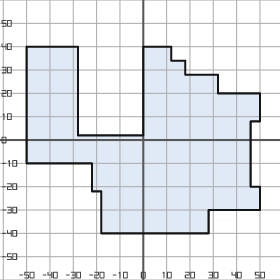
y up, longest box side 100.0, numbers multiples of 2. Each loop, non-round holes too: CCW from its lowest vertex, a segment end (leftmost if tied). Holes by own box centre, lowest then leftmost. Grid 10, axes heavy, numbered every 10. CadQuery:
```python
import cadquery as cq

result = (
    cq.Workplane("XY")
    .moveTo(-18.0, -40.0)
    .lineTo(28.0, -40.0)
    .lineTo(28.0, -30.0)
    .lineTo(50.0, -30.0)
    .lineTo(50.0, -20.0)
    .lineTo(46.0, -20.0)
    .lineTo(46.0, 8.0)
    .lineTo(50.0, 8.0)
    .lineTo(50.0, 20.0)
    .lineTo(32.0, 20.0)
    .lineTo(32.0, 28.0)
    .lineTo(18.0, 28.0)
    .lineTo(18.0, 34.0)
    .lineTo(12.0, 34.0)
    .lineTo(12.0, 40.0)
    .lineTo(0.0, 40.0)
    .lineTo(0.0, 2.0)
    .lineTo(-28.0, 2.0)
    .lineTo(-28.0, 40.0)
    .lineTo(-50.0, 40.0)
    .lineTo(-50.0, -10.0)
    .lineTo(-22.0, -10.0)
    .lineTo(-22.0, -22.0)
    .lineTo(-18.0, -22.0)
    .close()
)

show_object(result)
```